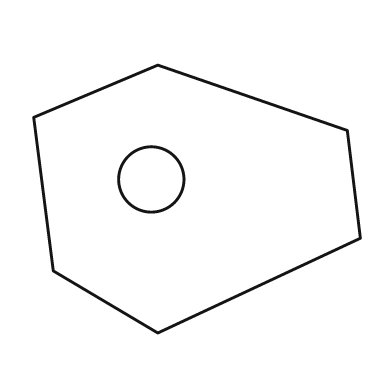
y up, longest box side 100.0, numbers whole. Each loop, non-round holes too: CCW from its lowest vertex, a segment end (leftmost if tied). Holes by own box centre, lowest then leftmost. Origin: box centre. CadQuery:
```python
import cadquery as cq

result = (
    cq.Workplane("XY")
    .moveTo(-12.0, -41.0)
    .lineTo(50.0, -12.0)
    .lineTo(46.0, 21.0)
    .lineTo(-12.0, 41.0)
    .lineTo(-50.0, 25.0)
    .lineTo(-44.0, -22.0)
    .close()
    .moveTo(-14.0, 6.0)
    .circle(10.0)
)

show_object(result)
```